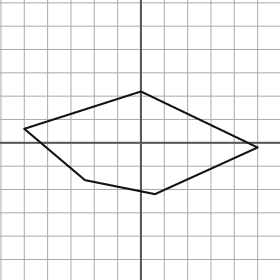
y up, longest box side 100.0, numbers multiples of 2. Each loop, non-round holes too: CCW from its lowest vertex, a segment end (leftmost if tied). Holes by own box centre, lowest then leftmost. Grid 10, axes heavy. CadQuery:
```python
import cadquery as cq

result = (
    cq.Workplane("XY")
    .moveTo(6.0, -22.0)
    .lineTo(50.0, -2.0)
    .lineTo(0.0, 22.0)
    .lineTo(-50.0, 6.0)
    .lineTo(-24.0, -16.0)
    .close()
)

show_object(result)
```